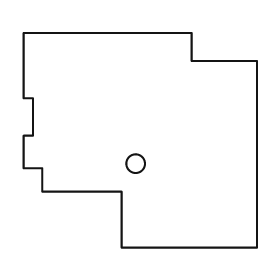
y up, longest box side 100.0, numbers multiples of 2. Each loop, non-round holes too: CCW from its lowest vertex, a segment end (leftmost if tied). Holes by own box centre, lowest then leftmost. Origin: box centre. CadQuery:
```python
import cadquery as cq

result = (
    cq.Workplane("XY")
    .moveTo(-8.0, -46.0)
    .lineTo(50.0, -46.0)
    .lineTo(50.0, 34.0)
    .lineTo(22.0, 34.0)
    .lineTo(22.0, 46.0)
    .lineTo(-50.0, 46.0)
    .lineTo(-50.0, 18.0)
    .lineTo(-46.0, 18.0)
    .lineTo(-46.0, 2.0)
    .lineTo(-50.0, 2.0)
    .lineTo(-50.0, -12.0)
    .lineTo(-42.0, -12.0)
    .lineTo(-42.0, -22.0)
    .lineTo(-8.0, -22.0)
    .close()
    .moveTo(-2.0, -10.0)
    .circle(4.0)
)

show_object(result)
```